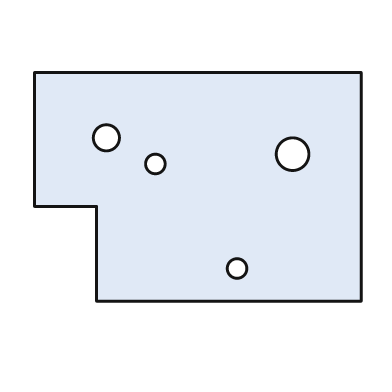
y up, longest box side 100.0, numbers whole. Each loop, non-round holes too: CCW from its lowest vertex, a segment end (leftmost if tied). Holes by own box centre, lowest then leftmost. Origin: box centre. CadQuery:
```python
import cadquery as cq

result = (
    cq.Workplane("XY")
    .moveTo(-31.0, -35.0)
    .lineTo(50.0, -35.0)
    .lineTo(50.0, 35.0)
    .lineTo(-50.0, 35.0)
    .lineTo(-50.0, -6.0)
    .lineTo(-31.0, -6.0)
    .close()
    .moveTo(12.0, -25.0)
    .circle(3.0)
    .moveTo(-13.0, 7.0)
    .circle(3.0)
    .moveTo(29.0, 10.0)
    .circle(5.0)
    .moveTo(-28.0, 15.0)
    .circle(4.0)
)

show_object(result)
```